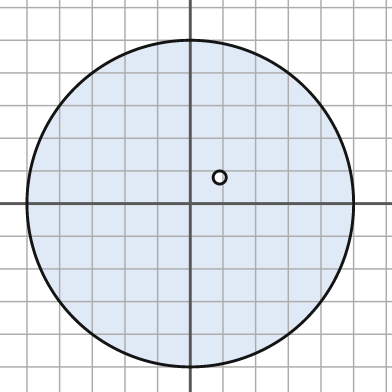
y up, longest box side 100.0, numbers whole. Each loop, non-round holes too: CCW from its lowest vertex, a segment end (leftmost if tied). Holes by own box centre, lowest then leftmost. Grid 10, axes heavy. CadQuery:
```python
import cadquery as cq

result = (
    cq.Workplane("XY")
    .moveTo(0.0, 0.0)
    .circle(50.0)
    .moveTo(9.0, 8.0)
    .circle(2.0)
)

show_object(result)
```